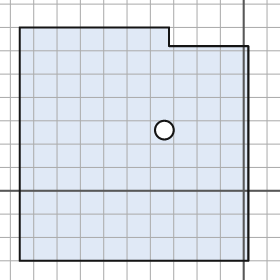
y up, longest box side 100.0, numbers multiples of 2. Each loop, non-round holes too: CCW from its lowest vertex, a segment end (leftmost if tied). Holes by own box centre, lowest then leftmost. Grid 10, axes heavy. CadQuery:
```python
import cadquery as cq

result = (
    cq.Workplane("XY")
    .moveTo(-96.0, -30.0)
    .lineTo(2.0, -30.0)
    .lineTo(2.0, 62.0)
    .lineTo(-32.0, 62.0)
    .lineTo(-32.0, 70.0)
    .lineTo(-96.0, 70.0)
    .close()
    .moveTo(-34.0, 26.0)
    .circle(4.0)
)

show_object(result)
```